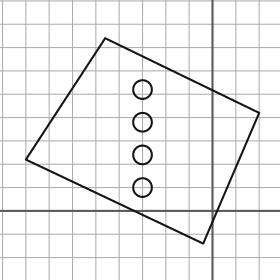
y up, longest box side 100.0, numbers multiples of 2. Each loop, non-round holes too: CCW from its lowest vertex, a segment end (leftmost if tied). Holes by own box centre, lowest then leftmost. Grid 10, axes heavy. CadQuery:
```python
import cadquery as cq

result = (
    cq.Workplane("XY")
    .moveTo(-4.0, -14.0)
    .lineTo(20.0, 42.0)
    .lineTo(-46.0, 74.0)
    .lineTo(-80.0, 22.0)
    .close()
    .moveTo(-30.0, 10.0)
    .circle(4.0)
    .moveTo(-30.0, 24.0)
    .circle(4.0)
    .moveTo(-30.0, 38.0)
    .circle(4.0)
    .moveTo(-30.0, 52.0)
    .circle(4.0)
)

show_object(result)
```